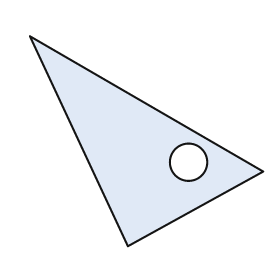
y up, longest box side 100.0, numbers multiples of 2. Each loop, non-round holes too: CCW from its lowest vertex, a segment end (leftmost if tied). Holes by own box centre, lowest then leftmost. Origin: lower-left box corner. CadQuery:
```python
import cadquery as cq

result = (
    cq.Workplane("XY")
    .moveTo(42.0, 0.0)
    .lineTo(100.0, 32.0)
    .lineTo(0.0, 90.0)
    .close()
    .moveTo(68.0, 36.0)
    .circle(8.0)
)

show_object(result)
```